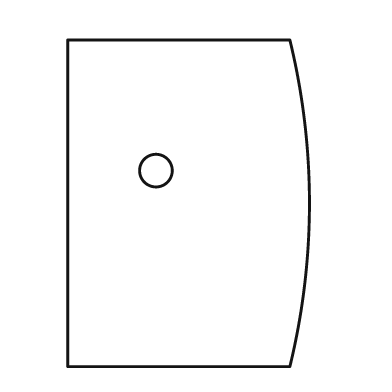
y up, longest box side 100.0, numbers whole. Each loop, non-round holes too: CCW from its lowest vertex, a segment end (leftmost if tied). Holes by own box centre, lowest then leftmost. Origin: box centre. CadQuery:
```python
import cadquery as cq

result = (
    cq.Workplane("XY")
    .moveTo(-37.0, -50.0)
    .lineTo(31.0, -50.0)
    .threePointArc((37.0, 0.0), (31.0, 50.0))
    .lineTo(-37.0, 50.0)
    .close()
    .moveTo(-10.0, 10.0)
    .circle(5.0)
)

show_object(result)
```